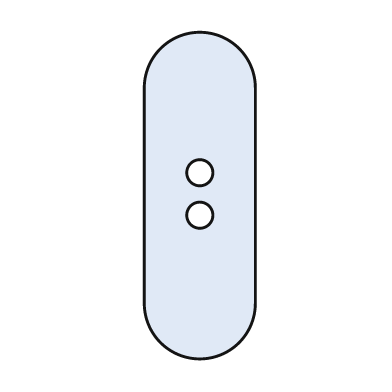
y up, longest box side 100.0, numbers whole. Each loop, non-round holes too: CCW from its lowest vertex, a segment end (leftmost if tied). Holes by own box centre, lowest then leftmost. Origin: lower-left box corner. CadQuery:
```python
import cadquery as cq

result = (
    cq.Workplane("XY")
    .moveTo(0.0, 17.0)
    .threePointArc((17.0, 0.0), (34.0, 17.0))
    .lineTo(34.0, 83.0)
    .threePointArc((17.0, 100.0), (0.0, 83.0))
    .close()
    .moveTo(17.0, 44.0)
    .circle(4.0)
    .moveTo(17.0, 57.0)
    .circle(4.0)
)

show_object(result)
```